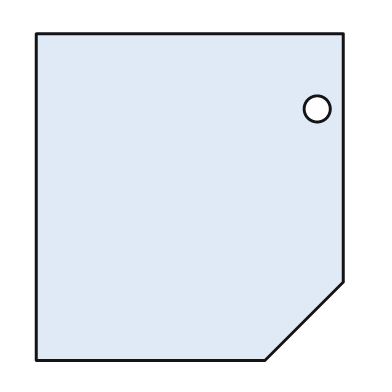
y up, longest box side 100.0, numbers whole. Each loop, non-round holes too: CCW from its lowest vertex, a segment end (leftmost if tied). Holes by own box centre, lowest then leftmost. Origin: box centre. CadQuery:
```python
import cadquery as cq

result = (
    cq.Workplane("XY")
    .moveTo(-47.0, -50.0)
    .lineTo(23.0, -50.0)
    .lineTo(47.0, -26.0)
    .lineTo(47.0, 50.0)
    .lineTo(-47.0, 50.0)
    .close()
    .moveTo(39.0, 27.0)
    .circle(4.0)
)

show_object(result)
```